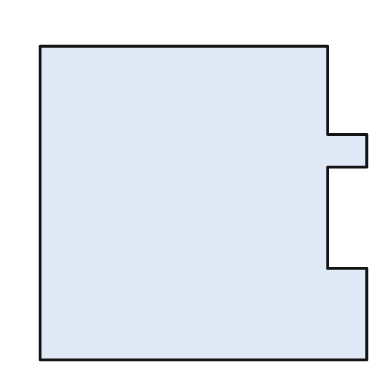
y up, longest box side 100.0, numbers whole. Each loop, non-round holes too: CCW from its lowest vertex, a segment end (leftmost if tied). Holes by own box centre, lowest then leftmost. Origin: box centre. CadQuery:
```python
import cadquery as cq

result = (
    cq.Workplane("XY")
    .moveTo(-50.0, -48.0)
    .lineTo(50.0, -48.0)
    .lineTo(50.0, -20.0)
    .lineTo(38.0, -20.0)
    .lineTo(38.0, 11.0)
    .lineTo(50.0, 11.0)
    .lineTo(50.0, 21.0)
    .lineTo(38.0, 21.0)
    .lineTo(38.0, 48.0)
    .lineTo(-50.0, 48.0)
    .close()
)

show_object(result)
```